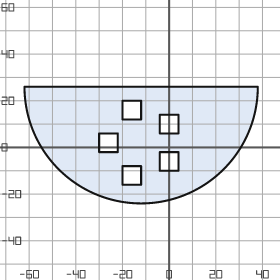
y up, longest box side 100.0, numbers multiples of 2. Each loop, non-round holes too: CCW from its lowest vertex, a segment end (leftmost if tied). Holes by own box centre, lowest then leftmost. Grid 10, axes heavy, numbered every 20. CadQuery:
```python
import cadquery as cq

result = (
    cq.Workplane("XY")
    .moveTo(-62.0, 26.0)
    .threePointArc((-12.0, -24.0), (38.0, 26.0))
    .close()
    .moveTo(-20.0, -16.0)
    .lineTo(-12.0, -16.0)
    .lineTo(-12.0, -8.0)
    .lineTo(-20.0, -8.0)
    .close()
    .moveTo(-4.0, -10.0)
    .lineTo(4.0, -10.0)
    .lineTo(4.0, -2.0)
    .lineTo(-4.0, -2.0)
    .close()
    .moveTo(-30.0, -2.0)
    .lineTo(-22.0, -2.0)
    .lineTo(-22.0, 6.0)
    .lineTo(-30.0, 6.0)
    .close()
    .moveTo(-4.0, 6.0)
    .lineTo(4.0, 6.0)
    .lineTo(4.0, 14.0)
    .lineTo(-4.0, 14.0)
    .close()
    .moveTo(-20.0, 12.0)
    .lineTo(-12.0, 12.0)
    .lineTo(-12.0, 20.0)
    .lineTo(-20.0, 20.0)
    .close()
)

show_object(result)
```